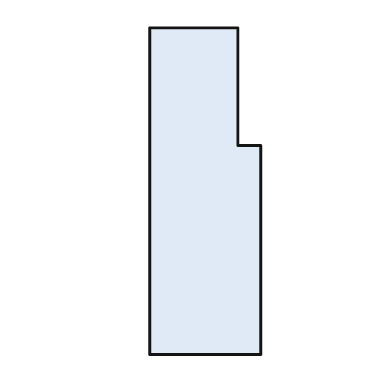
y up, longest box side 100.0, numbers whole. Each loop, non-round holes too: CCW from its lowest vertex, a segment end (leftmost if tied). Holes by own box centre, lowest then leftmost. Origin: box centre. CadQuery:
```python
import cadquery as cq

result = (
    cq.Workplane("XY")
    .moveTo(-17.0, -50.0)
    .lineTo(17.0, -50.0)
    .lineTo(17.0, 14.0)
    .lineTo(10.0, 14.0)
    .lineTo(10.0, 50.0)
    .lineTo(-17.0, 50.0)
    .close()
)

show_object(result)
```